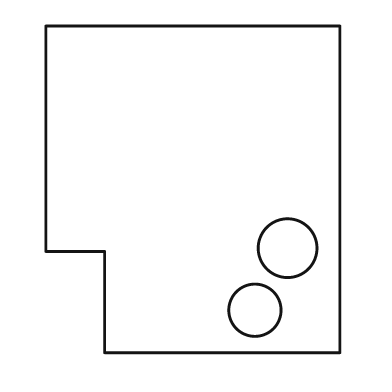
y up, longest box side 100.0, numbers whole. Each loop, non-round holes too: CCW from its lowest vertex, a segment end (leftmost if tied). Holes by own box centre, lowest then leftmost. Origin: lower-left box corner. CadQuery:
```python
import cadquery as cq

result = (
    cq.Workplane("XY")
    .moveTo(18.0, 0.0)
    .lineTo(90.0, 0.0)
    .lineTo(90.0, 100.0)
    .lineTo(0.0, 100.0)
    .lineTo(0.0, 31.0)
    .lineTo(18.0, 31.0)
    .close()
    .moveTo(64.0, 13.0)
    .circle(8.0)
    .moveTo(74.0, 32.0)
    .circle(9.0)
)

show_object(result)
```